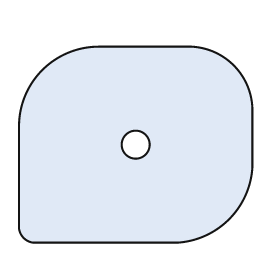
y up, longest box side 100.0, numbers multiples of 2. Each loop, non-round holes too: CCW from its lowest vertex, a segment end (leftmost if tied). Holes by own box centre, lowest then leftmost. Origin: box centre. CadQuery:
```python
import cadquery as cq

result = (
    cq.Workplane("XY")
    .moveTo(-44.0, -42.0)
    .lineTo(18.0, -42.0)
    .threePointArc((40.0, -32.0), (50.0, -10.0))
    .lineTo(50.0, 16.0)
    .threePointArc((42.0, 34.0), (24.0, 42.0))
    .lineTo(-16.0, 42.0)
    .threePointArc((-40.0, 32.0), (-50.0, 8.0))
    .lineTo(-50.0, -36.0)
    .threePointArc((-48.0, -40.0), (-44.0, -42.0))
    .close()
    .moveTo(0.0, 0.0)
    .circle(6.0)
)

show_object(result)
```